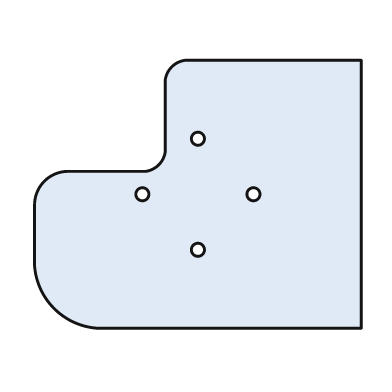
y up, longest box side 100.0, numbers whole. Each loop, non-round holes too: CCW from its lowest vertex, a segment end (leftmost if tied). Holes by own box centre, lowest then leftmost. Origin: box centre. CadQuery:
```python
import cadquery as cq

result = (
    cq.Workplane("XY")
    .moveTo(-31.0, -41.0)
    .lineTo(50.0, -41.0)
    .lineTo(50.0, 41.0)
    .lineTo(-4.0, 41.0)
    .threePointArc((-8.0, 39.0), (-10.0, 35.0))
    .lineTo(-10.0, 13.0)
    .threePointArc((-12.0, 9.0), (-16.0, 7.0))
    .lineTo(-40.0, 7.0)
    .threePointArc((-47.0, 4.0), (-50.0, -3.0))
    .lineTo(-50.0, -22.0)
    .threePointArc((-44.0, -35.0), (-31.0, -41.0))
    .close()
    .moveTo(0.0, -17.0)
    .circle(2.0)
    .moveTo(-17.0, 0.0)
    .circle(2.0)
    .moveTo(17.0, 0.0)
    .circle(2.0)
    .moveTo(0.0, 17.0)
    .circle(2.0)
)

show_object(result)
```